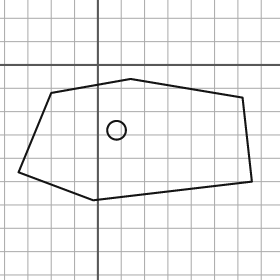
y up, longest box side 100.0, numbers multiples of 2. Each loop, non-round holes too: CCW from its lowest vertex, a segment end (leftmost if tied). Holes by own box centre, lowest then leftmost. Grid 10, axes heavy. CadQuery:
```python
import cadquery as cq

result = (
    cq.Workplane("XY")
    .moveTo(-2.0, -58.0)
    .lineTo(66.0, -50.0)
    .lineTo(62.0, -14.0)
    .lineTo(14.0, -6.0)
    .lineTo(-20.0, -12.0)
    .lineTo(-34.0, -46.0)
    .close()
    .moveTo(8.0, -28.0)
    .circle(4.0)
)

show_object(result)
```